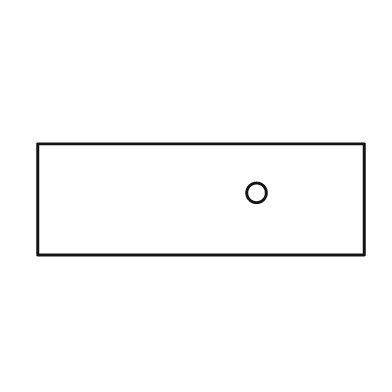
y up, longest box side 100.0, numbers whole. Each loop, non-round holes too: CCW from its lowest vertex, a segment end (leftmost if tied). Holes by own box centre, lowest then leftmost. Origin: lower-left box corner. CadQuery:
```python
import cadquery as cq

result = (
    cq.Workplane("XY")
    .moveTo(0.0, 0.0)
    .lineTo(100.0, 0.0)
    .lineTo(100.0, 34.0)
    .lineTo(0.0, 34.0)
    .close()
    .moveTo(67.0, 19.0)
    .circle(3.0)
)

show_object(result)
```